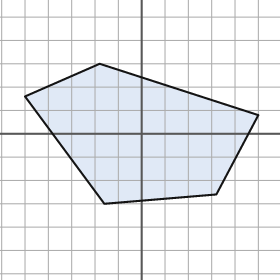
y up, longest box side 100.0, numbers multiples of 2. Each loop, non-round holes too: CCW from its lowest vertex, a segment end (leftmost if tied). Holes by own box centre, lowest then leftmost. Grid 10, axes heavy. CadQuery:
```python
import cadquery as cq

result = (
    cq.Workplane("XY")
    .moveTo(-16.0, -30.0)
    .lineTo(32.0, -26.0)
    .lineTo(50.0, 8.0)
    .lineTo(-18.0, 30.0)
    .lineTo(-50.0, 16.0)
    .close()
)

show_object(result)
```